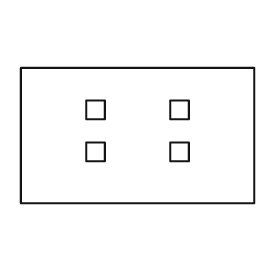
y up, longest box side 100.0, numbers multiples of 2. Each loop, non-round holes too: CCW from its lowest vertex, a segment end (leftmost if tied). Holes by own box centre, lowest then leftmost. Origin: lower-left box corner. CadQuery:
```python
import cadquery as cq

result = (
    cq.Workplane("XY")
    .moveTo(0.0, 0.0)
    .lineTo(100.0, 0.0)
    .lineTo(100.0, 58.0)
    .lineTo(0.0, 58.0)
    .close()
    .moveTo(28.0, 18.0)
    .lineTo(36.0, 18.0)
    .lineTo(36.0, 26.0)
    .lineTo(28.0, 26.0)
    .close()
    .moveTo(64.0, 18.0)
    .lineTo(72.0, 18.0)
    .lineTo(72.0, 26.0)
    .lineTo(64.0, 26.0)
    .close()
    .moveTo(28.0, 36.0)
    .lineTo(36.0, 36.0)
    .lineTo(36.0, 44.0)
    .lineTo(28.0, 44.0)
    .close()
    .moveTo(64.0, 36.0)
    .lineTo(72.0, 36.0)
    .lineTo(72.0, 44.0)
    .lineTo(64.0, 44.0)
    .close()
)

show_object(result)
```